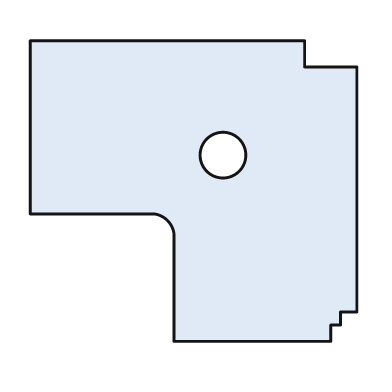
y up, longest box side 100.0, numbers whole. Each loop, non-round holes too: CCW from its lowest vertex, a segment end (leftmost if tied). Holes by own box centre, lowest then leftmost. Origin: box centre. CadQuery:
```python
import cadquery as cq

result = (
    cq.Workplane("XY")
    .moveTo(-6.0, -46.0)
    .lineTo(42.0, -46.0)
    .lineTo(42.0, -41.0)
    .lineTo(45.0, -41.0)
    .lineTo(45.0, -37.0)
    .lineTo(50.0, -37.0)
    .lineTo(50.0, 38.0)
    .lineTo(34.0, 38.0)
    .lineTo(34.0, 46.0)
    .lineTo(-50.0, 46.0)
    .lineTo(-50.0, -7.0)
    .lineTo(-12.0, -7.0)
    .threePointArc((-8.0, -9.0), (-6.0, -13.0))
    .close()
    .moveTo(9.0, 11.0)
    .circle(7.0)
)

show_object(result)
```